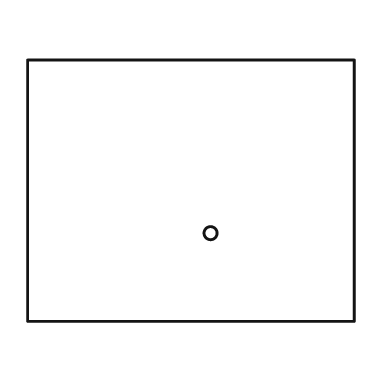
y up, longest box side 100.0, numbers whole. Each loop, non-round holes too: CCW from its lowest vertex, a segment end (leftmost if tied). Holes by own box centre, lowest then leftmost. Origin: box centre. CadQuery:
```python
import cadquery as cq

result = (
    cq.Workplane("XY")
    .moveTo(-50.0, -40.0)
    .lineTo(50.0, -40.0)
    .lineTo(50.0, 40.0)
    .lineTo(-50.0, 40.0)
    .close()
    .moveTo(6.0, -13.0)
    .circle(2.0)
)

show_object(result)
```